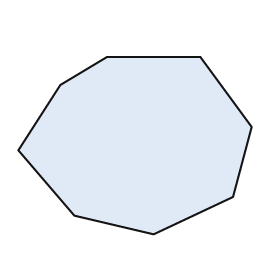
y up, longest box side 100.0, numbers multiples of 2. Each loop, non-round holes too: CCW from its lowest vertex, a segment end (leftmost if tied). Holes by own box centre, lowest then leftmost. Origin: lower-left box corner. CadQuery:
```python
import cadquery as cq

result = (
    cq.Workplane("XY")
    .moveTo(58.0, 0.0)
    .lineTo(92.0, 16.0)
    .lineTo(100.0, 46.0)
    .lineTo(78.0, 76.0)
    .lineTo(38.0, 76.0)
    .lineTo(18.0, 64.0)
    .lineTo(0.0, 36.0)
    .lineTo(24.0, 8.0)
    .close()
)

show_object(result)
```